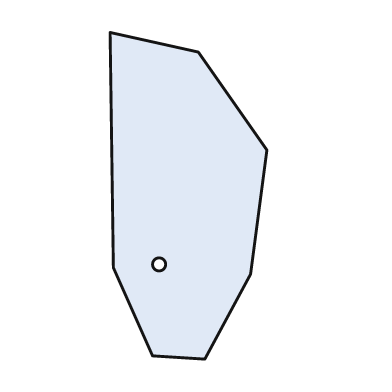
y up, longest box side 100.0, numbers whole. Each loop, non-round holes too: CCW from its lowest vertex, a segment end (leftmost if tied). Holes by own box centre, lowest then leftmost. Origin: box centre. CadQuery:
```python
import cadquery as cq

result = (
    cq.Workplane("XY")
    .moveTo(5.0, -50.0)
    .lineTo(19.0, -24.0)
    .lineTo(24.0, 14.0)
    .lineTo(3.0, 44.0)
    .lineTo(-24.0, 50.0)
    .lineTo(-23.0, -22.0)
    .lineTo(-11.0, -49.0)
    .close()
    .moveTo(-9.0, -21.0)
    .circle(2.0)
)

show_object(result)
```